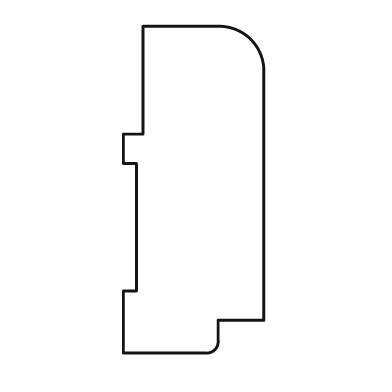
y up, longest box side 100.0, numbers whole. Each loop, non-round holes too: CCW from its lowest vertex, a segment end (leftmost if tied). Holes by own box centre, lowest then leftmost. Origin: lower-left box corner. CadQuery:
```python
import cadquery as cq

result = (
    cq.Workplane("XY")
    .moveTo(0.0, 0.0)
    .lineTo(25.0, 0.0)
    .threePointArc((28.0, 1.0), (29.0, 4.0))
    .lineTo(29.0, 10.0)
    .lineTo(43.0, 10.0)
    .lineTo(43.0, 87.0)
    .threePointArc((39.0, 96.0), (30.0, 100.0))
    .lineTo(6.0, 100.0)
    .lineTo(6.0, 67.0)
    .lineTo(0.0, 67.0)
    .lineTo(0.0, 58.0)
    .lineTo(4.0, 58.0)
    .lineTo(4.0, 19.0)
    .lineTo(0.0, 19.0)
    .close()
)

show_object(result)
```